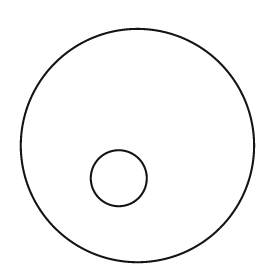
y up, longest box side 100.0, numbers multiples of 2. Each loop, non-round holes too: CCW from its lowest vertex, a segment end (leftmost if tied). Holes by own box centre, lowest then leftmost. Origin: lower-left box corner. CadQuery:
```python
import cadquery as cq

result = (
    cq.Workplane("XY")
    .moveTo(50.0, 50.0)
    .circle(50.0)
    .moveTo(42.0, 36.0)
    .circle(12.0)
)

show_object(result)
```